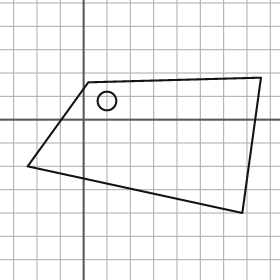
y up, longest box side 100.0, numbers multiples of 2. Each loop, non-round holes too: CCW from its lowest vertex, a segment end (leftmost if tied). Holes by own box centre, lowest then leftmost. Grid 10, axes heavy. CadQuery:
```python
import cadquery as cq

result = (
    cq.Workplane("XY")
    .moveTo(68.0, -40.0)
    .lineTo(76.0, 18.0)
    .lineTo(2.0, 16.0)
    .lineTo(-24.0, -20.0)
    .close()
    .moveTo(10.0, 8.0)
    .circle(4.0)
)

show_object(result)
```